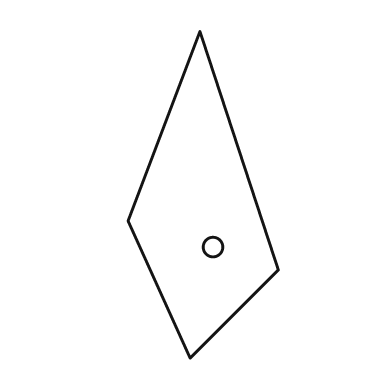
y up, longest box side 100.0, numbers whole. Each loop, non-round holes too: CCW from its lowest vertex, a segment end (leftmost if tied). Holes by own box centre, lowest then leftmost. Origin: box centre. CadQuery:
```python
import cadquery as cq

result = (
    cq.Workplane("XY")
    .moveTo(-4.0, -50.0)
    .lineTo(23.0, -23.0)
    .lineTo(-1.0, 50.0)
    .lineTo(-23.0, -8.0)
    .close()
    .moveTo(3.0, -16.0)
    .circle(3.0)
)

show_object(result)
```